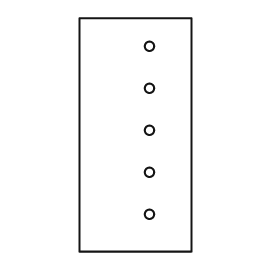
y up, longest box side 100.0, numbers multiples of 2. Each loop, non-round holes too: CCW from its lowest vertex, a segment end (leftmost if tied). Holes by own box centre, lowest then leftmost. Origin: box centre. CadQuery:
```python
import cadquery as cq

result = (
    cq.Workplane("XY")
    .moveTo(-24.0, -50.0)
    .lineTo(24.0, -50.0)
    .lineTo(24.0, 50.0)
    .lineTo(-24.0, 50.0)
    .close()
    .moveTo(6.0, -34.0)
    .circle(2.0)
    .moveTo(6.0, -16.0)
    .circle(2.0)
    .moveTo(6.0, 2.0)
    .circle(2.0)
    .moveTo(6.0, 20.0)
    .circle(2.0)
    .moveTo(6.0, 38.0)
    .circle(2.0)
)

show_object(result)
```